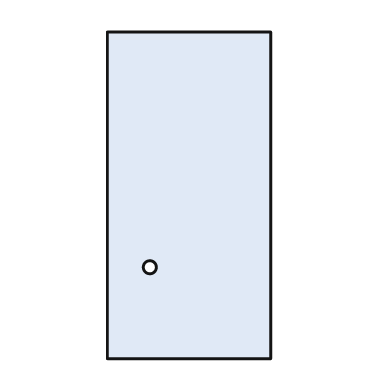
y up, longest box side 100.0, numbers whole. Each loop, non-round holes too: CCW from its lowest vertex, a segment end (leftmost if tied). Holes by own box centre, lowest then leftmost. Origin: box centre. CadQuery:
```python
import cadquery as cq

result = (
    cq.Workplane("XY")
    .moveTo(-25.0, -50.0)
    .lineTo(25.0, -50.0)
    .lineTo(25.0, 50.0)
    .lineTo(-25.0, 50.0)
    .close()
    .moveTo(-12.0, -22.0)
    .circle(2.0)
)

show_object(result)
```